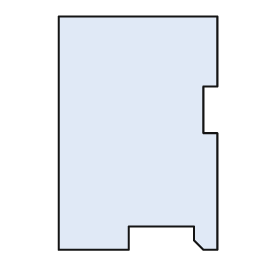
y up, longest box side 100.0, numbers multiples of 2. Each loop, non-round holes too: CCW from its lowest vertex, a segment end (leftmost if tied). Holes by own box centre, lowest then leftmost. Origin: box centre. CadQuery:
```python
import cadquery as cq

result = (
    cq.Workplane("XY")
    .moveTo(-34.0, -50.0)
    .lineTo(-4.0, -50.0)
    .lineTo(-4.0, -40.0)
    .lineTo(24.0, -40.0)
    .lineTo(24.0, -46.0)
    .lineTo(28.0, -50.0)
    .lineTo(34.0, -50.0)
    .lineTo(34.0, 0.0)
    .lineTo(28.0, 0.0)
    .lineTo(28.0, 20.0)
    .lineTo(34.0, 20.0)
    .lineTo(34.0, 50.0)
    .lineTo(-34.0, 50.0)
    .close()
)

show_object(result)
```